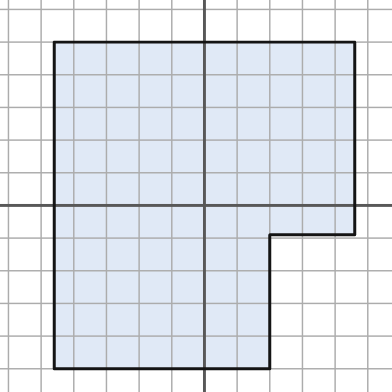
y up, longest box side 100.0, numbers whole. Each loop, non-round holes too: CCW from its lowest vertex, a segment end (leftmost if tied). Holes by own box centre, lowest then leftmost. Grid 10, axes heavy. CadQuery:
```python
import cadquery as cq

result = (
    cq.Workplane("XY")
    .moveTo(-46.0, -50.0)
    .lineTo(20.0, -50.0)
    .lineTo(20.0, -9.0)
    .lineTo(46.0, -9.0)
    .lineTo(46.0, 50.0)
    .lineTo(-46.0, 50.0)
    .close()
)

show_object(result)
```